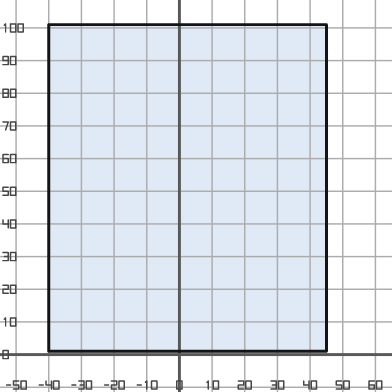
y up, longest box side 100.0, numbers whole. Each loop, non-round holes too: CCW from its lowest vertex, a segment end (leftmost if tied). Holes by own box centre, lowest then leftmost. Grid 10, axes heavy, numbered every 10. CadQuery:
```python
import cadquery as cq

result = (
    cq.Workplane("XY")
    .moveTo(-40.0, 1.0)
    .lineTo(45.0, 1.0)
    .lineTo(45.0, 101.0)
    .lineTo(-40.0, 101.0)
    .close()
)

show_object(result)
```